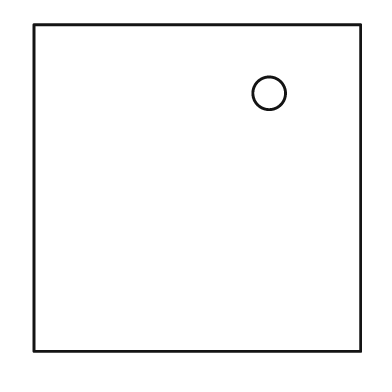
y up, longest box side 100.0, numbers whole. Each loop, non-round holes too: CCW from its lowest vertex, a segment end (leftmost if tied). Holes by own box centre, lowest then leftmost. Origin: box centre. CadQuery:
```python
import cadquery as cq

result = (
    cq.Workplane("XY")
    .moveTo(-50.0, -50.0)
    .lineTo(50.0, -50.0)
    .lineTo(50.0, 50.0)
    .lineTo(-50.0, 50.0)
    .close()
    .moveTo(22.0, 29.0)
    .circle(5.0)
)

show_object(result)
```